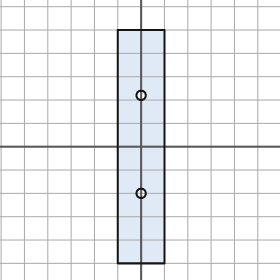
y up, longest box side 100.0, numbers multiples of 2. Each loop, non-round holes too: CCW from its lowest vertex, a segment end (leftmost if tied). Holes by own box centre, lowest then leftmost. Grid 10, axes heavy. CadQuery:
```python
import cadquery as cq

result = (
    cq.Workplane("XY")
    .moveTo(-10.0, -50.0)
    .lineTo(10.0, -50.0)
    .lineTo(10.0, 50.0)
    .lineTo(-10.0, 50.0)
    .close()
    .moveTo(0.0, -20.0)
    .circle(2.0)
    .moveTo(0.0, 22.0)
    .circle(2.0)
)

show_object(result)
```